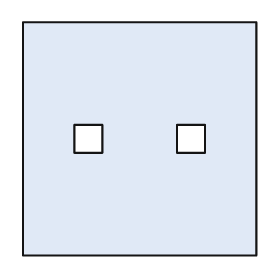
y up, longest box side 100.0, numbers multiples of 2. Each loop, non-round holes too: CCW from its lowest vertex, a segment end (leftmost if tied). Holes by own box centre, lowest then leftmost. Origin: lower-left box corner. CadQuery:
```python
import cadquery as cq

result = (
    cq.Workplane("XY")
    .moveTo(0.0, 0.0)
    .lineTo(100.0, 0.0)
    .lineTo(100.0, 100.0)
    .lineTo(0.0, 100.0)
    .close()
    .moveTo(22.0, 44.0)
    .lineTo(34.0, 44.0)
    .lineTo(34.0, 56.0)
    .lineTo(22.0, 56.0)
    .close()
    .moveTo(66.0, 44.0)
    .lineTo(78.0, 44.0)
    .lineTo(78.0, 56.0)
    .lineTo(66.0, 56.0)
    .close()
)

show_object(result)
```